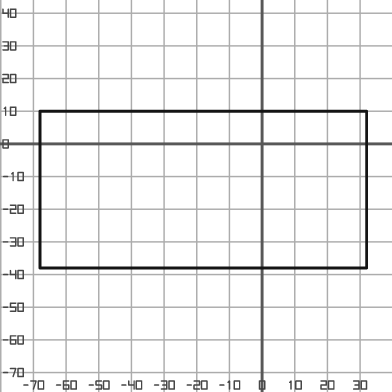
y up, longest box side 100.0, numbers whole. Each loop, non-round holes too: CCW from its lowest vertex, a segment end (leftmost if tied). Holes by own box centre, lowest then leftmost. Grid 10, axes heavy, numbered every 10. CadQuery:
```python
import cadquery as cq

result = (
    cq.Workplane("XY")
    .moveTo(-68.0, -38.0)
    .lineTo(32.0, -38.0)
    .lineTo(32.0, 10.0)
    .lineTo(-68.0, 10.0)
    .close()
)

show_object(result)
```